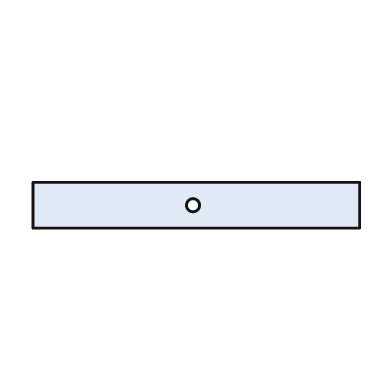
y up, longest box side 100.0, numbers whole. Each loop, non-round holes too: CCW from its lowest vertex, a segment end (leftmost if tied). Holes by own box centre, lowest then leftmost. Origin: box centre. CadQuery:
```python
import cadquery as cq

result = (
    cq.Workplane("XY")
    .moveTo(-50.0, -7.0)
    .lineTo(50.0, -7.0)
    .lineTo(50.0, 7.0)
    .lineTo(-50.0, 7.0)
    .close()
    .moveTo(-1.0, 0.0)
    .circle(2.0)
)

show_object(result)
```